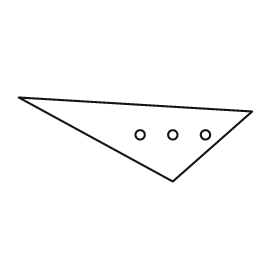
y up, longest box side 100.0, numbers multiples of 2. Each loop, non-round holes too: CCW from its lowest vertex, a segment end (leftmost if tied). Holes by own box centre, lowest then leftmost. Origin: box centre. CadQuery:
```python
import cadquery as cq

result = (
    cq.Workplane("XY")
    .moveTo(16.0, -18.0)
    .lineTo(50.0, 12.0)
    .lineTo(-50.0, 18.0)
    .close()
    .moveTo(2.0, 2.0)
    .circle(2.0)
    .moveTo(16.0, 2.0)
    .circle(2.0)
    .moveTo(30.0, 2.0)
    .circle(2.0)
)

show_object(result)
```